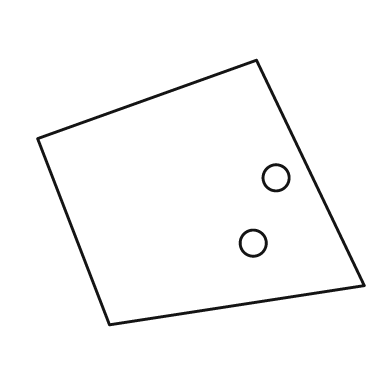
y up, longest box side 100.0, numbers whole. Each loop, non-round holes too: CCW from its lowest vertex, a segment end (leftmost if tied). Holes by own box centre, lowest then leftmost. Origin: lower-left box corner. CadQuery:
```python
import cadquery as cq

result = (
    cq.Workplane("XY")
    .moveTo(22.0, 0.0)
    .lineTo(100.0, 12.0)
    .lineTo(67.0, 81.0)
    .lineTo(0.0, 57.0)
    .close()
    .moveTo(66.0, 25.0)
    .circle(4.0)
    .moveTo(73.0, 45.0)
    .circle(4.0)
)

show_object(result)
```